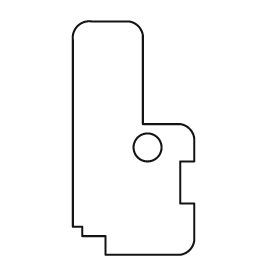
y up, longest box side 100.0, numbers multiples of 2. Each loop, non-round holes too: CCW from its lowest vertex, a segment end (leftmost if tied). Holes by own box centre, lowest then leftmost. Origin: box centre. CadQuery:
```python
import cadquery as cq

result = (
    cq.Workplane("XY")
    .moveTo(-12.0, -50.0)
    .lineTo(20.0, -50.0)
    .threePointArc((24.0, -48.0), (26.0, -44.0))
    .lineTo(26.0, -28.0)
    .lineTo(20.0, -28.0)
    .lineTo(20.0, -10.0)
    .lineTo(26.0, -10.0)
    .lineTo(26.0, 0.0)
    .threePointArc((24.0, 4.0), (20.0, 6.0))
    .lineTo(4.0, 6.0)
    .lineTo(4.0, 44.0)
    .threePointArc((2.0, 48.0), (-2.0, 50.0))
    .lineTo(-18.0, 50.0)
    .threePointArc((-24.0, 48.0), (-26.0, 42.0))
    .lineTo(-26.0, -38.0)
    .lineTo(-22.0, -38.0)
    .lineTo(-22.0, -42.0)
    .lineTo(-12.0, -42.0)
    .close()
    .moveTo(6.0, -4.0)
    .circle(6.0)
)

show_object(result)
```